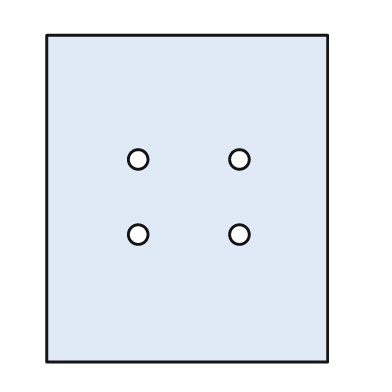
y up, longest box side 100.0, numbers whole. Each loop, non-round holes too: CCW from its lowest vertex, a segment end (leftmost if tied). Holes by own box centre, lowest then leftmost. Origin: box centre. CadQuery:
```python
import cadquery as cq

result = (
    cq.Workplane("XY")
    .moveTo(-43.0, -50.0)
    .lineTo(43.0, -50.0)
    .lineTo(43.0, 50.0)
    .lineTo(-43.0, 50.0)
    .close()
    .moveTo(-15.0, -11.0)
    .circle(3.0)
    .moveTo(16.0, -11.0)
    .circle(3.0)
    .moveTo(-15.0, 12.0)
    .circle(3.0)
    .moveTo(16.0, 12.0)
    .circle(3.0)
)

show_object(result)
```